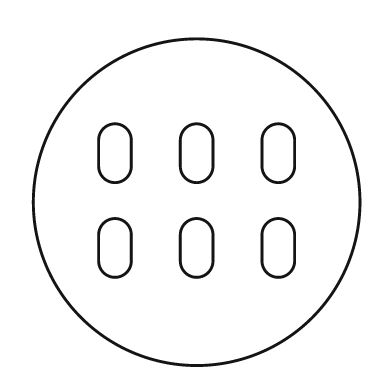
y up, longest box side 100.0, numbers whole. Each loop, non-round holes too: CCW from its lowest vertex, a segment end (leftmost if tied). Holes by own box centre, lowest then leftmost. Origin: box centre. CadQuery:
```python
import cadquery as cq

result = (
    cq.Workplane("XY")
    .moveTo(0.0, 0.0)
    .circle(50.0)
    .moveTo(-30.0, -18.0)
    .threePointArc((-25.0, -23.0), (-20.0, -18.0))
    .lineTo(-20.0, -10.0)
    .threePointArc((-25.0, -5.0), (-30.0, -10.0))
    .close()
    .moveTo(-5.0, -18.0)
    .threePointArc((0.0, -23.0), (5.0, -18.0))
    .lineTo(5.0, -10.0)
    .threePointArc((0.0, -5.0), (-5.0, -10.0))
    .close()
    .moveTo(20.0, -18.0)
    .threePointArc((25.0, -23.0), (30.0, -18.0))
    .lineTo(30.0, -10.0)
    .threePointArc((25.0, -5.0), (20.0, -10.0))
    .close()
    .moveTo(-30.0, 11.0)
    .threePointArc((-25.0, 6.0), (-20.0, 11.0))
    .lineTo(-20.0, 19.0)
    .threePointArc((-25.0, 24.0), (-30.0, 19.0))
    .close()
    .moveTo(-5.0, 11.0)
    .threePointArc((0.0, 6.0), (5.0, 11.0))
    .lineTo(5.0, 19.0)
    .threePointArc((0.0, 24.0), (-5.0, 19.0))
    .close()
    .moveTo(20.0, 11.0)
    .threePointArc((25.0, 6.0), (30.0, 11.0))
    .lineTo(30.0, 19.0)
    .threePointArc((25.0, 24.0), (20.0, 19.0))
    .close()
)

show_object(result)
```